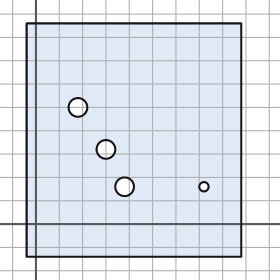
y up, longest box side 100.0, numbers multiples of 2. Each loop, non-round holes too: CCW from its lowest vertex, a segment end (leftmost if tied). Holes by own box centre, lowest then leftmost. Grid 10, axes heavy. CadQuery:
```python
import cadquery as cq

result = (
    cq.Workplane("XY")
    .moveTo(-4.0, -14.0)
    .lineTo(88.0, -14.0)
    .lineTo(88.0, 86.0)
    .lineTo(-4.0, 86.0)
    .close()
    .moveTo(38.0, 16.0)
    .circle(4.0)
    .moveTo(72.0, 16.0)
    .circle(2.0)
    .moveTo(30.0, 32.0)
    .circle(4.0)
    .moveTo(18.0, 50.0)
    .circle(4.0)
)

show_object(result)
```